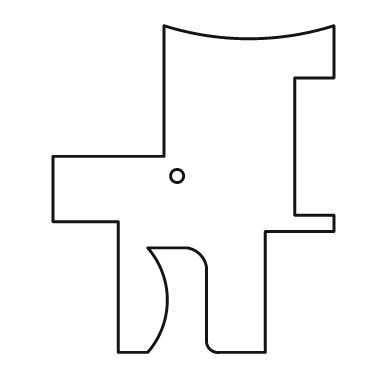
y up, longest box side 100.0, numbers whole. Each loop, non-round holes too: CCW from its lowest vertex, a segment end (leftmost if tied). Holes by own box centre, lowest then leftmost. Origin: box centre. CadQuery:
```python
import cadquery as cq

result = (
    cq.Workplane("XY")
    .moveTo(-23.0, -50.0)
    .lineTo(-14.0, -50.0)
    .threePointArc((-8.0, -34.0), (-14.0, -18.0))
    .lineTo(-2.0, -18.0)
    .threePointArc((2.0, -20.0), (4.0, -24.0))
    .lineTo(4.0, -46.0)
    .threePointArc((5.0, -49.0), (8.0, -50.0))
    .lineTo(22.0, -50.0)
    .lineTo(22.0, -13.0)
    .lineTo(43.0, -13.0)
    .lineTo(43.0, -8.0)
    .lineTo(31.0, -8.0)
    .lineTo(31.0, 34.0)
    .lineTo(43.0, 34.0)
    .lineTo(43.0, 50.0)
    .threePointArc((17.0, 46.0), (-9.0, 50.0))
    .lineTo(-9.0, 10.0)
    .lineTo(-43.0, 10.0)
    .lineTo(-43.0, -10.0)
    .lineTo(-23.0, -10.0)
    .close()
    .moveTo(-5.0, 4.0)
    .circle(2.0)
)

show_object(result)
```